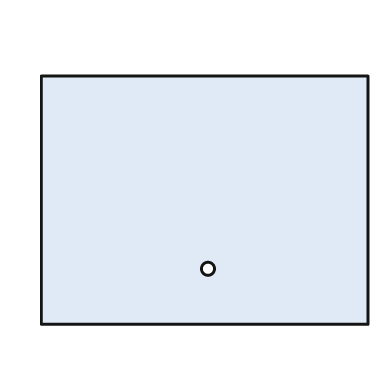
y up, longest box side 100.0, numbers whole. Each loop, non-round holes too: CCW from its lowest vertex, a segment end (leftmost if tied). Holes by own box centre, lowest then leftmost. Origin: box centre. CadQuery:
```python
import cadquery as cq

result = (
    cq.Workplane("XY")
    .moveTo(-50.0, -38.0)
    .lineTo(50.0, -38.0)
    .lineTo(50.0, 38.0)
    .lineTo(-50.0, 38.0)
    .close()
    .moveTo(1.0, -21.0)
    .circle(2.0)
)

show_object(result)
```